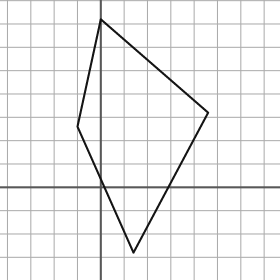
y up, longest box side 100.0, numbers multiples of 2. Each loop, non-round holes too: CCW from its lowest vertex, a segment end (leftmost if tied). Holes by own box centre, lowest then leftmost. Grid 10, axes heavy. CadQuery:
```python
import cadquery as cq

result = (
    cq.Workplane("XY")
    .moveTo(14.0, -28.0)
    .lineTo(46.0, 32.0)
    .lineTo(0.0, 72.0)
    .lineTo(-10.0, 26.0)
    .close()
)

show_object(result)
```